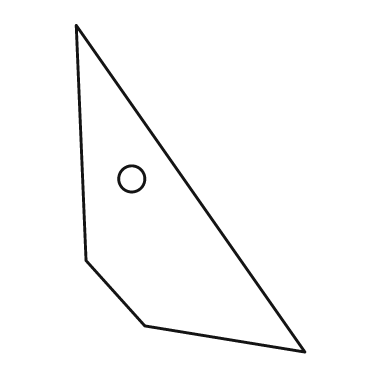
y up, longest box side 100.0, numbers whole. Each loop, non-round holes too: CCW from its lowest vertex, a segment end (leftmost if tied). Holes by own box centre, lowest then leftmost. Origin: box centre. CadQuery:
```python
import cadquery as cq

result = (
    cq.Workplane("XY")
    .moveTo(35.0, -50.0)
    .lineTo(-35.0, 50.0)
    .lineTo(-32.0, -22.0)
    .lineTo(-14.0, -42.0)
    .close()
    .moveTo(-18.0, 3.0)
    .circle(4.0)
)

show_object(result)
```